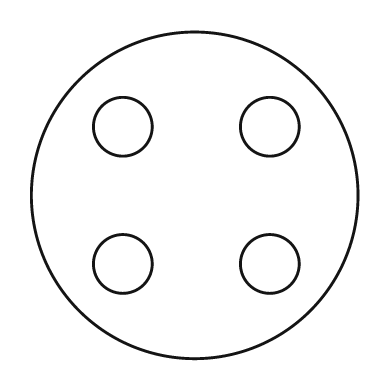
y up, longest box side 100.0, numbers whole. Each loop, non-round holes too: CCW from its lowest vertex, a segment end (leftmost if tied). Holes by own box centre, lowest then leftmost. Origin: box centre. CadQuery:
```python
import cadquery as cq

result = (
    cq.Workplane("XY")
    .moveTo(0.0, 0.0)
    .circle(50.0)
    .moveTo(-22.0, -21.0)
    .circle(9.0)
    .moveTo(23.0, -21.0)
    .circle(9.0)
    .moveTo(-22.0, 21.0)
    .circle(9.0)
    .moveTo(23.0, 21.0)
    .circle(9.0)
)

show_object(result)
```